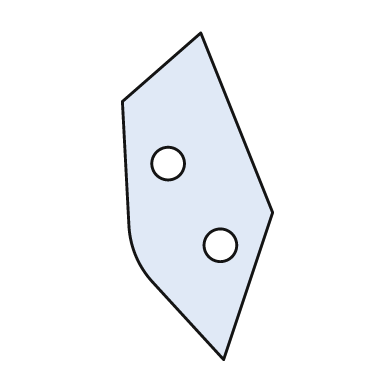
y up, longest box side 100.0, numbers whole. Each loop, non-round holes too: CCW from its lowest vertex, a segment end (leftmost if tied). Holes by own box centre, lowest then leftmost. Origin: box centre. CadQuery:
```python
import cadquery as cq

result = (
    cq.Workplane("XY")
    .moveTo(8.0, -50.0)
    .lineTo(23.0, -5.0)
    .lineTo(1.0, 50.0)
    .lineTo(-23.0, 29.0)
    .lineTo(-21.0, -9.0)
    .threePointArc((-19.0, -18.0), (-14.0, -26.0))
    .close()
    .moveTo(7.0, -15.0)
    .circle(5.0)
    .moveTo(-9.0, 10.0)
    .circle(5.0)
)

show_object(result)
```